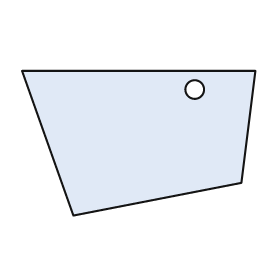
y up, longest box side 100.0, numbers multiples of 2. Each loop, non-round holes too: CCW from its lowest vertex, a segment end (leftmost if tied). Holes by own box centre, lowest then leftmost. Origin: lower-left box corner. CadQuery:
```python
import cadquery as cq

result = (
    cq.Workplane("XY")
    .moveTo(22.0, 0.0)
    .lineTo(94.0, 14.0)
    .lineTo(100.0, 62.0)
    .lineTo(0.0, 62.0)
    .close()
    .moveTo(74.0, 54.0)
    .circle(4.0)
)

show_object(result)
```